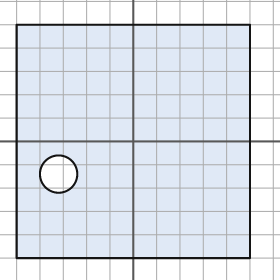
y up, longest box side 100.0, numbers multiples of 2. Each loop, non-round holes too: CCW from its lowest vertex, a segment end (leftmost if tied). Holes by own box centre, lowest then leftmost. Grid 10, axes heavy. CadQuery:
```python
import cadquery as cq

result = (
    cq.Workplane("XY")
    .moveTo(-50.0, -50.0)
    .lineTo(50.0, -50.0)
    .lineTo(50.0, 50.0)
    .lineTo(-50.0, 50.0)
    .close()
    .moveTo(-32.0, -14.0)
    .circle(8.0)
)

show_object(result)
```